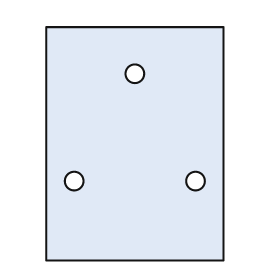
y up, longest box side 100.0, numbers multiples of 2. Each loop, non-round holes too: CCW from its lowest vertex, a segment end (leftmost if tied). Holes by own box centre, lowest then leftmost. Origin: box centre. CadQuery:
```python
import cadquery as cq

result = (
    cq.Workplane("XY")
    .moveTo(-38.0, -50.0)
    .lineTo(38.0, -50.0)
    .lineTo(38.0, 50.0)
    .lineTo(-38.0, 50.0)
    .close()
    .moveTo(-26.0, -16.0)
    .circle(4.0)
    .moveTo(26.0, -16.0)
    .circle(4.0)
    .moveTo(0.0, 30.0)
    .circle(4.0)
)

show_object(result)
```